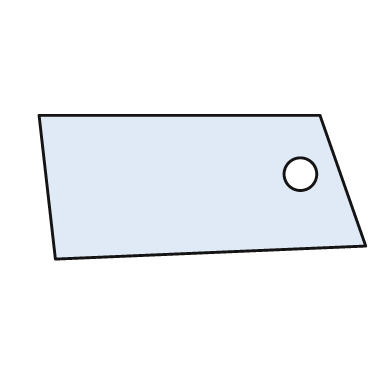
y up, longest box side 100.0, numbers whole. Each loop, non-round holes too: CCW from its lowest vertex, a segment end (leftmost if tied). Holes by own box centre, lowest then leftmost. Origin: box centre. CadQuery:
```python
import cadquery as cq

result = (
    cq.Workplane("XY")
    .moveTo(-45.0, -22.0)
    .lineTo(50.0, -18.0)
    .lineTo(36.0, 22.0)
    .lineTo(-50.0, 22.0)
    .close()
    .moveTo(30.0, 4.0)
    .circle(5.0)
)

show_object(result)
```